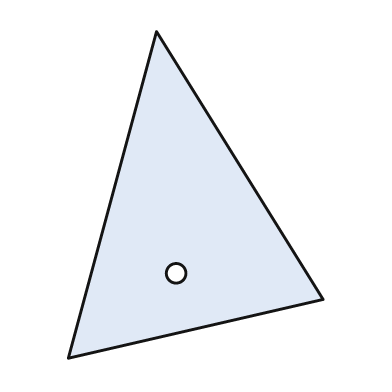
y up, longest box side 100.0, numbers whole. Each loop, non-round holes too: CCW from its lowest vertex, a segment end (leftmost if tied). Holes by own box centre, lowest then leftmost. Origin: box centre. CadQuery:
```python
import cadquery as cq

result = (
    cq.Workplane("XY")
    .moveTo(-39.0, -50.0)
    .lineTo(39.0, -32.0)
    .lineTo(-12.0, 50.0)
    .close()
    .moveTo(-6.0, -24.0)
    .circle(3.0)
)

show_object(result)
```